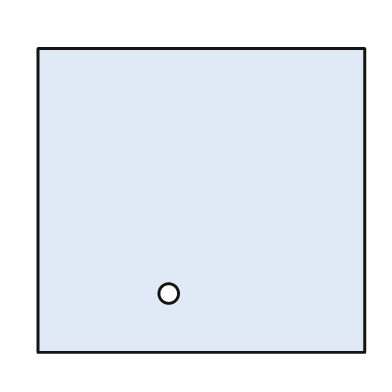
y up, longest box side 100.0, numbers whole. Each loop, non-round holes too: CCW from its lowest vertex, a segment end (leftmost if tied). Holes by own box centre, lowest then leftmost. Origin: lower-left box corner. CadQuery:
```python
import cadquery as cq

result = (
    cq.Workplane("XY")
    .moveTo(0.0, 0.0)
    .lineTo(100.0, 0.0)
    .lineTo(100.0, 93.0)
    .lineTo(0.0, 93.0)
    .close()
    .moveTo(40.0, 18.0)
    .circle(3.0)
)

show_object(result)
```